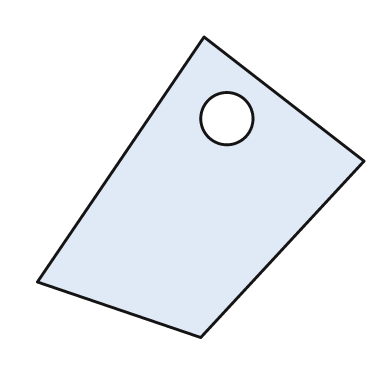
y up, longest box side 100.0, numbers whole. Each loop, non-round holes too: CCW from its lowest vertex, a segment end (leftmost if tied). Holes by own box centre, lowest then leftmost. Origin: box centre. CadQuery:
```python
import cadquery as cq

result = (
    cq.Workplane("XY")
    .moveTo(0.0, -46.0)
    .lineTo(50.0, 8.0)
    .lineTo(1.0, 46.0)
    .lineTo(-50.0, -29.0)
    .close()
    .moveTo(8.0, 21.0)
    .circle(8.0)
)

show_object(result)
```